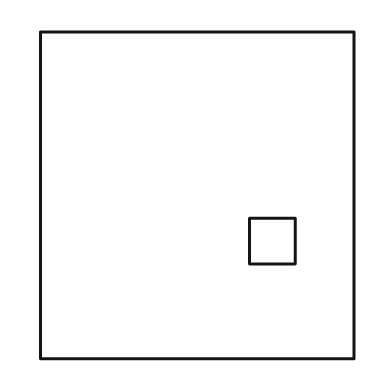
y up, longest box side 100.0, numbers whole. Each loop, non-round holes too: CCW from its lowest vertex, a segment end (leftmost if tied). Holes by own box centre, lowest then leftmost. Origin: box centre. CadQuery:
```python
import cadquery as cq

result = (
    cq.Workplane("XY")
    .moveTo(-48.0, -50.0)
    .lineTo(48.0, -50.0)
    .lineTo(48.0, 50.0)
    .lineTo(-48.0, 50.0)
    .close()
    .moveTo(16.0, -21.0)
    .lineTo(30.0, -21.0)
    .lineTo(30.0, -7.0)
    .lineTo(16.0, -7.0)
    .close()
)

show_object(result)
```